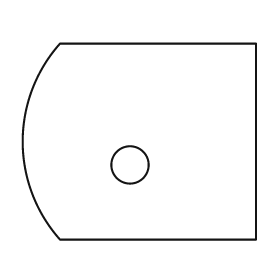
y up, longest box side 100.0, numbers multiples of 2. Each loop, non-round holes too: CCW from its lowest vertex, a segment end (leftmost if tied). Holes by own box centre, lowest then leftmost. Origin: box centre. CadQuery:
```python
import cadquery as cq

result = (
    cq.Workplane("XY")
    .moveTo(-34.0, -42.0)
    .lineTo(50.0, -42.0)
    .lineTo(50.0, 42.0)
    .lineTo(-34.0, 42.0)
    .threePointArc((-50.0, 0.0), (-34.0, -42.0))
    .close()
    .moveTo(-4.0, -10.0)
    .circle(8.0)
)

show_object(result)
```